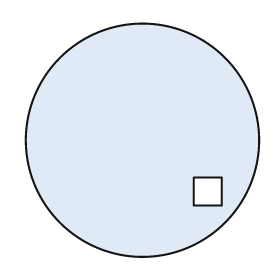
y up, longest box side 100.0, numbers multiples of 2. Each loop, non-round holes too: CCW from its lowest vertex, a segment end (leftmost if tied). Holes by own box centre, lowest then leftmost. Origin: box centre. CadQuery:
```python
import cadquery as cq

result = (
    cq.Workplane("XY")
    .moveTo(0.0, 0.0)
    .circle(50.0)
    .moveTo(22.0, -28.0)
    .lineTo(34.0, -28.0)
    .lineTo(34.0, -16.0)
    .lineTo(22.0, -16.0)
    .close()
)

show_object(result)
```